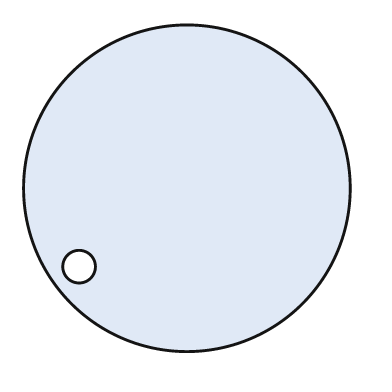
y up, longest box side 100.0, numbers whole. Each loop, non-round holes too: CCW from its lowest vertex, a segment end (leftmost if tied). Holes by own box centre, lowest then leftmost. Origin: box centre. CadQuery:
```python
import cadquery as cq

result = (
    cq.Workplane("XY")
    .moveTo(0.0, 0.0)
    .circle(50.0)
    .moveTo(-33.0, -24.0)
    .circle(5.0)
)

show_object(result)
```